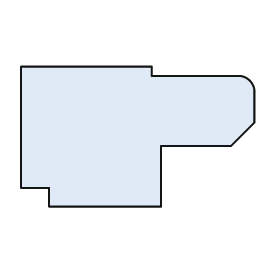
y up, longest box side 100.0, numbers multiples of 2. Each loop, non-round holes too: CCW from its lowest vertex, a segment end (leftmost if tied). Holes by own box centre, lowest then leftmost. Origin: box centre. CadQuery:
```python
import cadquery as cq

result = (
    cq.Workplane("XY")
    .moveTo(-38.0, -30.0)
    .lineTo(10.0, -30.0)
    .lineTo(10.0, -4.0)
    .lineTo(40.0, -4.0)
    .lineTo(50.0, 6.0)
    .lineTo(50.0, 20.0)
    .threePointArc((48.0, 24.0), (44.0, 26.0))
    .lineTo(6.0, 26.0)
    .lineTo(6.0, 30.0)
    .lineTo(-50.0, 30.0)
    .lineTo(-50.0, -22.0)
    .lineTo(-38.0, -22.0)
    .close()
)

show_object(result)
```